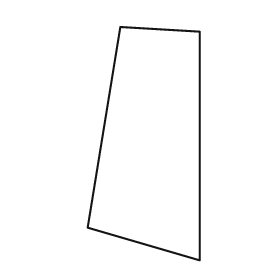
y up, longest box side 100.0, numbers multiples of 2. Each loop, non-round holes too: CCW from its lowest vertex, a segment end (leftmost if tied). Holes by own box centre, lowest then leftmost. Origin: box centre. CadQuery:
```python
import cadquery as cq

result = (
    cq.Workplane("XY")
    .moveTo(24.0, -50.0)
    .lineTo(24.0, 48.0)
    .lineTo(-10.0, 50.0)
    .lineTo(-24.0, -36.0)
    .close()
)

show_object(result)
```